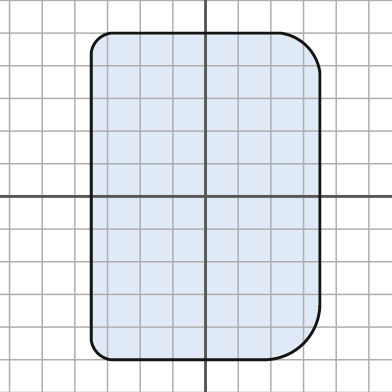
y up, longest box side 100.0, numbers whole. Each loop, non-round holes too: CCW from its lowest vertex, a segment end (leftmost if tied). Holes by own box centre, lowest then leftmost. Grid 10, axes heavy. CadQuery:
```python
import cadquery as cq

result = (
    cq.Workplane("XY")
    .moveTo(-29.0, -50.0)
    .lineTo(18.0, -50.0)
    .threePointArc((30.0, -45.0), (35.0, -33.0))
    .lineTo(35.0, 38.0)
    .threePointArc((31.0, 46.0), (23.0, 50.0))
    .lineTo(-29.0, 50.0)
    .threePointArc((-33.0, 48.0), (-35.0, 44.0))
    .lineTo(-35.0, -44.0)
    .threePointArc((-33.0, -48.0), (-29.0, -50.0))
    .close()
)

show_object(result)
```